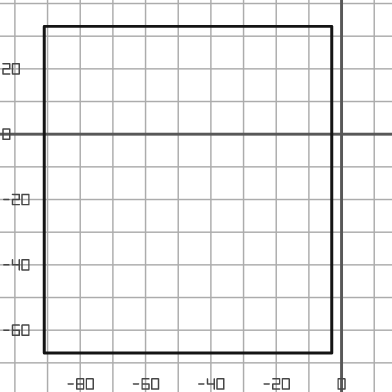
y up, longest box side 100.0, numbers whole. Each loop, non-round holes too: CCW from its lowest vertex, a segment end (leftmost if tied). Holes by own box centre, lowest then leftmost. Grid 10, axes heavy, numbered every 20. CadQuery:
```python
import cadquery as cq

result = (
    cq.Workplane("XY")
    .moveTo(-91.0, -67.0)
    .lineTo(-3.0, -67.0)
    .lineTo(-3.0, 33.0)
    .lineTo(-91.0, 33.0)
    .close()
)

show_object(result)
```